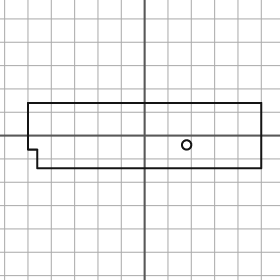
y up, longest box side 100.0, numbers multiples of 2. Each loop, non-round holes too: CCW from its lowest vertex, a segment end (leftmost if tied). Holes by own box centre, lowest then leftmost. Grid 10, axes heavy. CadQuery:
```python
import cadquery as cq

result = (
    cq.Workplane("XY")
    .moveTo(-46.0, -14.0)
    .lineTo(50.0, -14.0)
    .lineTo(50.0, 14.0)
    .lineTo(-50.0, 14.0)
    .lineTo(-50.0, -6.0)
    .lineTo(-46.0, -6.0)
    .close()
    .moveTo(18.0, -4.0)
    .circle(2.0)
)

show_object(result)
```